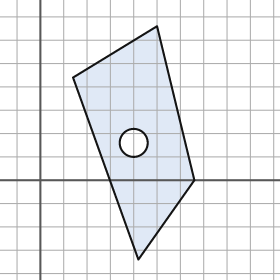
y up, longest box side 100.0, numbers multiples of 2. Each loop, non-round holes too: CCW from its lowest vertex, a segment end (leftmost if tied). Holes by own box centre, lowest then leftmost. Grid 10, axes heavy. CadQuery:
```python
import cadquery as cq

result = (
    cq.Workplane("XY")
    .moveTo(42.0, -34.0)
    .lineTo(66.0, 0.0)
    .lineTo(50.0, 66.0)
    .lineTo(14.0, 44.0)
    .close()
    .moveTo(40.0, 16.0)
    .circle(6.0)
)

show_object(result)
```